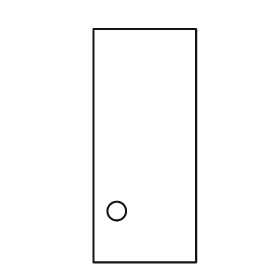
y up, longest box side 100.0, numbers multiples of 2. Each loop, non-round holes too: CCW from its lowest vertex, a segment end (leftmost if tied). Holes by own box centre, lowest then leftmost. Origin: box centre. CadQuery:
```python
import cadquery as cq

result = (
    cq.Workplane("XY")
    .moveTo(-22.0, -50.0)
    .lineTo(22.0, -50.0)
    .lineTo(22.0, 50.0)
    .lineTo(-22.0, 50.0)
    .close()
    .moveTo(-12.0, -28.0)
    .circle(4.0)
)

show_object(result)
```